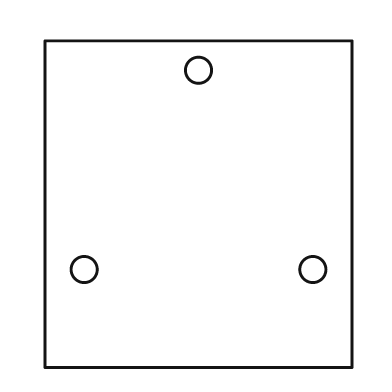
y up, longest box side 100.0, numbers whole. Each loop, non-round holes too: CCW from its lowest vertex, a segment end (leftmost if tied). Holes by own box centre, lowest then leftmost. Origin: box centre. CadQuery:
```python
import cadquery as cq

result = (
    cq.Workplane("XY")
    .moveTo(-47.0, -50.0)
    .lineTo(47.0, -50.0)
    .lineTo(47.0, 50.0)
    .lineTo(-47.0, 50.0)
    .close()
    .moveTo(-35.0, -20.0)
    .circle(4.0)
    .moveTo(35.0, -20.0)
    .circle(4.0)
    .moveTo(0.0, 41.0)
    .circle(4.0)
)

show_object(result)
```